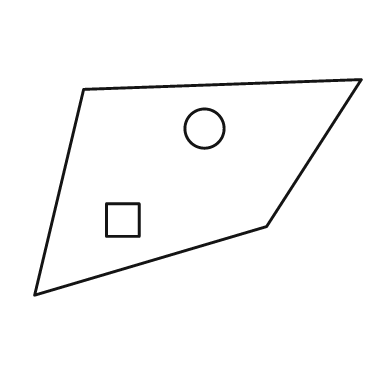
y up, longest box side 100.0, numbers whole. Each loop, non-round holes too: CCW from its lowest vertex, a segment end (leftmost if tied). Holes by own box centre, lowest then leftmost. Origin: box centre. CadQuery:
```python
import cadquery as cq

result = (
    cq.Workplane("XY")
    .moveTo(-50.0, -33.0)
    .lineTo(21.0, -12.0)
    .lineTo(50.0, 33.0)
    .lineTo(-35.0, 30.0)
    .close()
    .moveTo(-28.0, -15.0)
    .lineTo(-18.0, -15.0)
    .lineTo(-18.0, -5.0)
    .lineTo(-28.0, -5.0)
    .close()
    .moveTo(2.0, 18.0)
    .circle(6.0)
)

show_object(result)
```